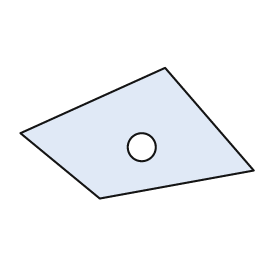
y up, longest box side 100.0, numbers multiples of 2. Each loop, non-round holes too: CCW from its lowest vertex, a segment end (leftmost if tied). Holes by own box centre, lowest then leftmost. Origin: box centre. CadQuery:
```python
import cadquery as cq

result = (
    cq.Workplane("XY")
    .moveTo(-16.0, -28.0)
    .lineTo(50.0, -16.0)
    .lineTo(12.0, 28.0)
    .lineTo(-50.0, 0.0)
    .close()
    .moveTo(2.0, -6.0)
    .circle(6.0)
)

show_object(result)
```